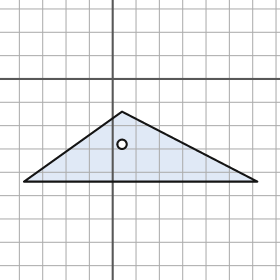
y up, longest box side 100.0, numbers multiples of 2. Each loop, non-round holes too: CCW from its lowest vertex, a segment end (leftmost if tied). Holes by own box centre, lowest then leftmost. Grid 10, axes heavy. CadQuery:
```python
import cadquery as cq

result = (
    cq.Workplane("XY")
    .moveTo(-38.0, -44.0)
    .lineTo(62.0, -44.0)
    .lineTo(4.0, -14.0)
    .close()
    .moveTo(4.0, -28.0)
    .circle(2.0)
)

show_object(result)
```